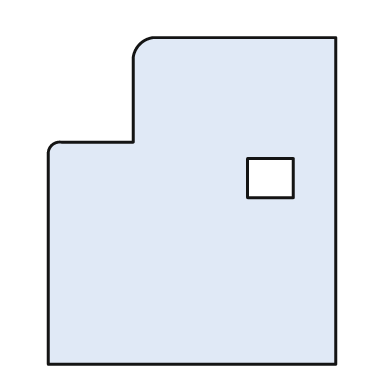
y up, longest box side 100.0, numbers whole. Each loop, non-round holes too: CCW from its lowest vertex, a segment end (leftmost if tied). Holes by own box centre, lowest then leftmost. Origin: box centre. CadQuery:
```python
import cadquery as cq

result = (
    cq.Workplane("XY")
    .moveTo(-44.0, -50.0)
    .lineTo(44.0, -50.0)
    .lineTo(44.0, 50.0)
    .lineTo(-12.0, 50.0)
    .threePointArc((-16.0, 48.0), (-18.0, 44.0))
    .lineTo(-18.0, 18.0)
    .lineTo(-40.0, 18.0)
    .threePointArc((-43.0, 17.0), (-44.0, 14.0))
    .close()
    .moveTo(17.0, 1.0)
    .lineTo(31.0, 1.0)
    .lineTo(31.0, 13.0)
    .lineTo(17.0, 13.0)
    .close()
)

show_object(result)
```